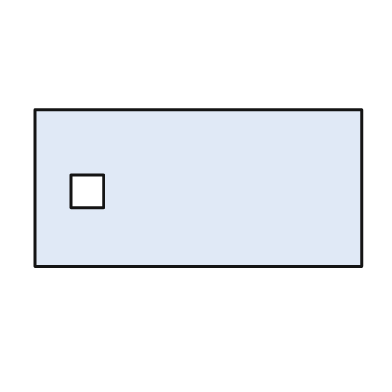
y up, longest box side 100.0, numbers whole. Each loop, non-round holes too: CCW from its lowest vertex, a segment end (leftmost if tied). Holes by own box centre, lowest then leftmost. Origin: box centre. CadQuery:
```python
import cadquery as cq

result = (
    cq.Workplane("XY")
    .moveTo(-50.0, -24.0)
    .lineTo(50.0, -24.0)
    .lineTo(50.0, 24.0)
    .lineTo(-50.0, 24.0)
    .close()
    .moveTo(-39.0, -6.0)
    .lineTo(-29.0, -6.0)
    .lineTo(-29.0, 4.0)
    .lineTo(-39.0, 4.0)
    .close()
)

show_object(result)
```